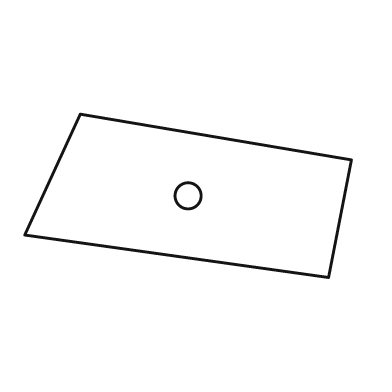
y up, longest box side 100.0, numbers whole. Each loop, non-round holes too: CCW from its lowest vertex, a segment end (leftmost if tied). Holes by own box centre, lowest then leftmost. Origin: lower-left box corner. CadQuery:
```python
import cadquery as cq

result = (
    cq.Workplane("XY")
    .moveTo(93.0, 0.0)
    .lineTo(100.0, 36.0)
    .lineTo(17.0, 50.0)
    .lineTo(0.0, 13.0)
    .close()
    .moveTo(50.0, 25.0)
    .circle(4.0)
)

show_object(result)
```